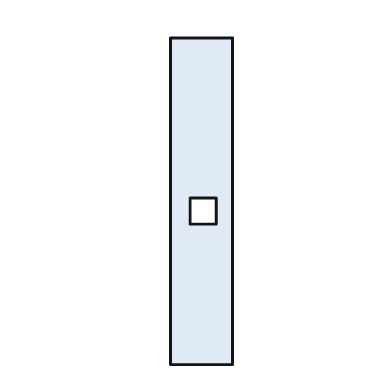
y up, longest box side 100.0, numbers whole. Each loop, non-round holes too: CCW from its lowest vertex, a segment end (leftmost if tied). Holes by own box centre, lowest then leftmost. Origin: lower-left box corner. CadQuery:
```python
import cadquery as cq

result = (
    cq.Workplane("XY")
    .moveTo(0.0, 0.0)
    .lineTo(19.0, 0.0)
    .lineTo(19.0, 100.0)
    .lineTo(0.0, 100.0)
    .close()
    .moveTo(6.0, 43.0)
    .lineTo(14.0, 43.0)
    .lineTo(14.0, 51.0)
    .lineTo(6.0, 51.0)
    .close()
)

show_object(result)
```